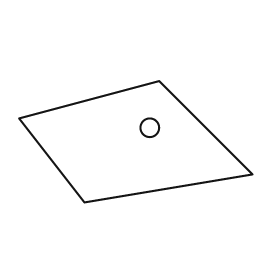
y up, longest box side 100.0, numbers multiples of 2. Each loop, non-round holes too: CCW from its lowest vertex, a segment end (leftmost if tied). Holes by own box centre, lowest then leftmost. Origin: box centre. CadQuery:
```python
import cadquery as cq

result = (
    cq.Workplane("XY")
    .moveTo(-22.0, -26.0)
    .lineTo(50.0, -14.0)
    .lineTo(10.0, 26.0)
    .lineTo(-50.0, 10.0)
    .close()
    .moveTo(6.0, 6.0)
    .circle(4.0)
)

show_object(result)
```